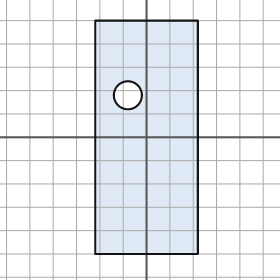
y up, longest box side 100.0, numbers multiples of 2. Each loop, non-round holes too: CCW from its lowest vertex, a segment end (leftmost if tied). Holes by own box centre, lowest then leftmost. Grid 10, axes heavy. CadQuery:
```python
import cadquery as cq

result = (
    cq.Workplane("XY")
    .moveTo(-22.0, -50.0)
    .lineTo(22.0, -50.0)
    .lineTo(22.0, 50.0)
    .lineTo(-22.0, 50.0)
    .close()
    .moveTo(-8.0, 18.0)
    .circle(6.0)
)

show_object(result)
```